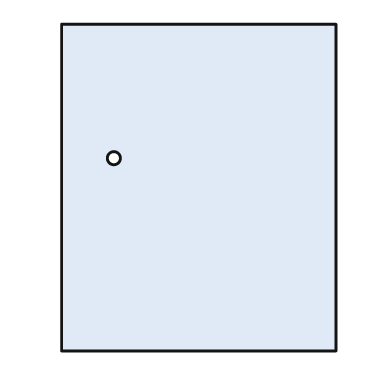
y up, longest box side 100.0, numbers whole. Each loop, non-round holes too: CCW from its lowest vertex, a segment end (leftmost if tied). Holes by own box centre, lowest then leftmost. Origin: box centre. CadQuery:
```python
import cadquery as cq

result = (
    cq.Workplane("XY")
    .moveTo(-42.0, -50.0)
    .lineTo(42.0, -50.0)
    .lineTo(42.0, 50.0)
    .lineTo(-42.0, 50.0)
    .close()
    .moveTo(-26.0, 9.0)
    .circle(2.0)
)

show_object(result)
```